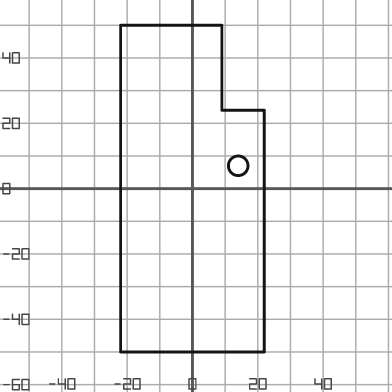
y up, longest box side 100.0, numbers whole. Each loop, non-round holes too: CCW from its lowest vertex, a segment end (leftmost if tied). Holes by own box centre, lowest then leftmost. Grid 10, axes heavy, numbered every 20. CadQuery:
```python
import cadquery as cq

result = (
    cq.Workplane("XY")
    .moveTo(-22.0, -50.0)
    .lineTo(22.0, -50.0)
    .lineTo(22.0, 24.0)
    .lineTo(9.0, 24.0)
    .lineTo(9.0, 50.0)
    .lineTo(-22.0, 50.0)
    .close()
    .moveTo(14.0, 7.0)
    .circle(3.0)
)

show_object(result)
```